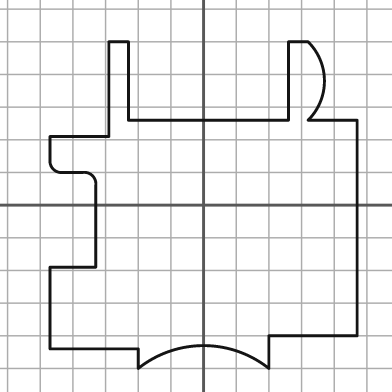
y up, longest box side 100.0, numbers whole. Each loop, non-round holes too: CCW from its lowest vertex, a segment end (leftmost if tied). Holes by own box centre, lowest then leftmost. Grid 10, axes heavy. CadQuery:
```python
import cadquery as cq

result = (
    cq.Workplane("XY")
    .moveTo(-20.0, -50.0)
    .threePointArc((0.0, -43.0), (20.0, -50.0))
    .lineTo(20.0, -40.0)
    .lineTo(47.0, -40.0)
    .lineTo(47.0, 26.0)
    .lineTo(32.0, 26.0)
    .threePointArc((37.0, 38.0), (32.0, 50.0))
    .lineTo(26.0, 50.0)
    .lineTo(26.0, 26.0)
    .lineTo(-23.0, 26.0)
    .lineTo(-23.0, 50.0)
    .lineTo(-29.0, 50.0)
    .lineTo(-29.0, 21.0)
    .lineTo(-47.0, 21.0)
    .lineTo(-47.0, 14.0)
    .threePointArc((-46.0, 11.0), (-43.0, 10.0))
    .lineTo(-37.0, 10.0)
    .threePointArc((-34.0, 9.0), (-33.0, 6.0))
    .lineTo(-33.0, -19.0)
    .lineTo(-47.0, -19.0)
    .lineTo(-47.0, -44.0)
    .lineTo(-20.0, -44.0)
    .close()
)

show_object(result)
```